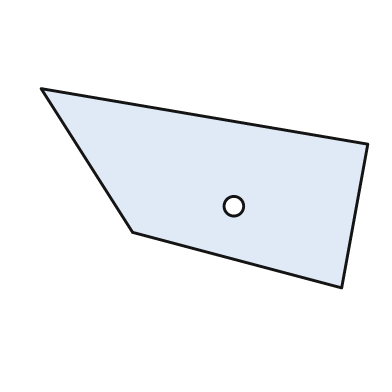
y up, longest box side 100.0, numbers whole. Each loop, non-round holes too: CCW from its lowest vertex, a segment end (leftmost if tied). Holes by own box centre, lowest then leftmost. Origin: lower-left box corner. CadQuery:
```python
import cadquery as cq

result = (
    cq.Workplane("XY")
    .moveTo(92.0, 0.0)
    .lineTo(100.0, 44.0)
    .lineTo(0.0, 61.0)
    .lineTo(28.0, 17.0)
    .close()
    .moveTo(59.0, 25.0)
    .circle(3.0)
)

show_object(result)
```